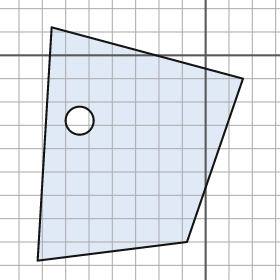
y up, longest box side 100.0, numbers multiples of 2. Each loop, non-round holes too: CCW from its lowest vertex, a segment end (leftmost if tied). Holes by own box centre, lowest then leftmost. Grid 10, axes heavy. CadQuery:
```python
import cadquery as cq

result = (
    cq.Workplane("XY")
    .moveTo(-72.0, -88.0)
    .lineTo(-8.0, -80.0)
    .lineTo(16.0, -10.0)
    .lineTo(-66.0, 12.0)
    .close()
    .moveTo(-54.0, -28.0)
    .circle(6.0)
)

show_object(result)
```